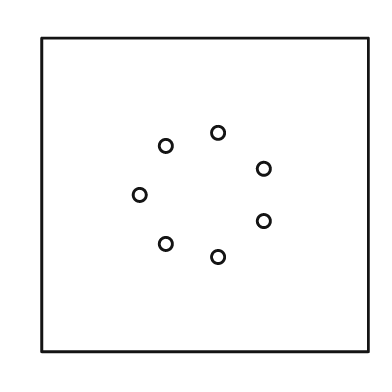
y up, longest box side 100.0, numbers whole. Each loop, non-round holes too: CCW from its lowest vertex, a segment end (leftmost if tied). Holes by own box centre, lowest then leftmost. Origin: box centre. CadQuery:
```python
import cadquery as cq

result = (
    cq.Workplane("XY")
    .moveTo(-50.0, -48.0)
    .lineTo(50.0, -48.0)
    .lineTo(50.0, 48.0)
    .lineTo(-50.0, 48.0)
    .close()
    .moveTo(4.0, -19.0)
    .circle(2.0)
    .moveTo(-12.0, -15.0)
    .circle(2.0)
    .moveTo(18.0, -8.0)
    .circle(2.0)
    .moveTo(-20.0, 0.0)
    .circle(2.0)
    .moveTo(18.0, 8.0)
    .circle(2.0)
    .moveTo(-12.0, 15.0)
    .circle(2.0)
    .moveTo(4.0, 19.0)
    .circle(2.0)
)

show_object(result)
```